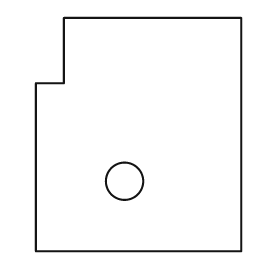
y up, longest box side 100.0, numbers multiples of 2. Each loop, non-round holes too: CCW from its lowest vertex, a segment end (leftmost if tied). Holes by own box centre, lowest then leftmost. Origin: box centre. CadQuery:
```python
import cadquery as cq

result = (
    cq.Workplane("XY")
    .moveTo(-44.0, -50.0)
    .lineTo(44.0, -50.0)
    .lineTo(44.0, 50.0)
    .lineTo(-32.0, 50.0)
    .lineTo(-32.0, 22.0)
    .lineTo(-44.0, 22.0)
    .close()
    .moveTo(-6.0, -20.0)
    .circle(8.0)
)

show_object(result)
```